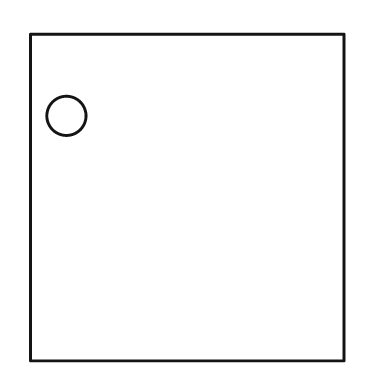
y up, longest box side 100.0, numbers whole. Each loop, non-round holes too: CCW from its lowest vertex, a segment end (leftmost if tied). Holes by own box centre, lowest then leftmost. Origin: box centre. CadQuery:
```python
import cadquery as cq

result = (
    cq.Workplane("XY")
    .moveTo(-48.0, -50.0)
    .lineTo(48.0, -50.0)
    .lineTo(48.0, 50.0)
    .lineTo(-48.0, 50.0)
    .close()
    .moveTo(-37.0, 25.0)
    .circle(6.0)
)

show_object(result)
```